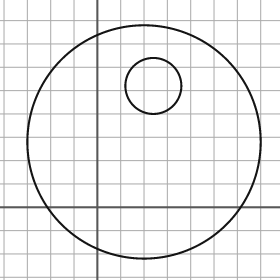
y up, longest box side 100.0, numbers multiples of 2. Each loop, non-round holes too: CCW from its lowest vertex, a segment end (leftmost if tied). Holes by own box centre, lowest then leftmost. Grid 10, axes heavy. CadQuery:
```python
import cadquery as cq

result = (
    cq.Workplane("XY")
    .moveTo(20.0, 28.0)
    .circle(50.0)
    .moveTo(24.0, 52.0)
    .circle(12.0)
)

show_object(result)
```